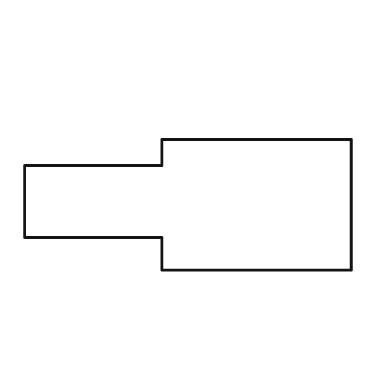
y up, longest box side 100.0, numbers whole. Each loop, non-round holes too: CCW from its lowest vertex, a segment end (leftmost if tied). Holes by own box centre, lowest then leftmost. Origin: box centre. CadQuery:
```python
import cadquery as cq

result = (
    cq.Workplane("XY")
    .moveTo(-8.0, -20.0)
    .lineTo(50.0, -20.0)
    .lineTo(50.0, 20.0)
    .lineTo(-8.0, 20.0)
    .lineTo(-8.0, 12.0)
    .lineTo(-50.0, 12.0)
    .lineTo(-50.0, -10.0)
    .lineTo(-8.0, -10.0)
    .close()
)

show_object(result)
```